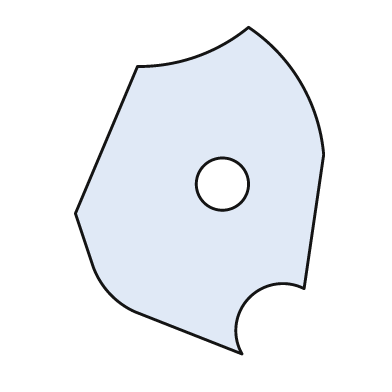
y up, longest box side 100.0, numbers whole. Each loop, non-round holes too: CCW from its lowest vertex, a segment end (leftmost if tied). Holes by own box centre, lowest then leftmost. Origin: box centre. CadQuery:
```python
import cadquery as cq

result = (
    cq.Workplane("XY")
    .moveTo(13.0, -50.0)
    .threePointArc((15.0, -33.0), (32.0, -30.0))
    .lineTo(38.0, 11.0)
    .threePointArc((31.0, 33.0), (15.0, 50.0))
    .threePointArc((-1.0, 41.0), (-19.0, 38.0))
    .lineTo(-38.0, -7.0)
    .lineTo(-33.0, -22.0)
    .threePointArc((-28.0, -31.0), (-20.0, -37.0))
    .close()
    .moveTo(7.0, 2.0)
    .circle(8.0)
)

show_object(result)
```